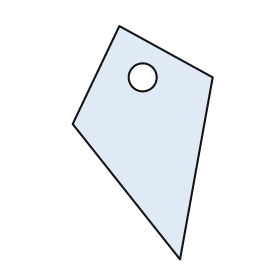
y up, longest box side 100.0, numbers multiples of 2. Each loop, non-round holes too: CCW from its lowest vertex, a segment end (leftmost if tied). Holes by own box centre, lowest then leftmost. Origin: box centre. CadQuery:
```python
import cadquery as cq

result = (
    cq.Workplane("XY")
    .moveTo(16.0, -50.0)
    .lineTo(30.0, 28.0)
    .lineTo(-10.0, 50.0)
    .lineTo(-30.0, 8.0)
    .close()
    .moveTo(0.0, 28.0)
    .circle(6.0)
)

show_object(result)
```